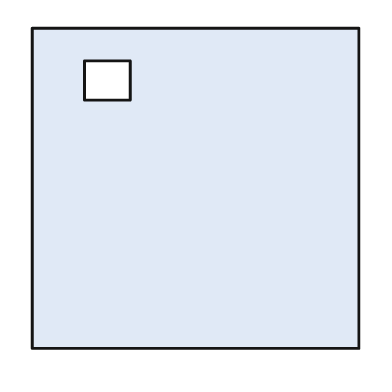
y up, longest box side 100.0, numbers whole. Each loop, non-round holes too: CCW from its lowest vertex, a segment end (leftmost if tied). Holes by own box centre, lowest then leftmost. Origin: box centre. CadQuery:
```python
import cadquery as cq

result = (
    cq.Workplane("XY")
    .moveTo(-50.0, -49.0)
    .lineTo(50.0, -49.0)
    .lineTo(50.0, 49.0)
    .lineTo(-50.0, 49.0)
    .close()
    .moveTo(-34.0, 27.0)
    .lineTo(-20.0, 27.0)
    .lineTo(-20.0, 39.0)
    .lineTo(-34.0, 39.0)
    .close()
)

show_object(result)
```